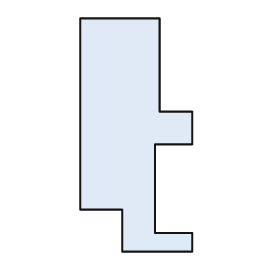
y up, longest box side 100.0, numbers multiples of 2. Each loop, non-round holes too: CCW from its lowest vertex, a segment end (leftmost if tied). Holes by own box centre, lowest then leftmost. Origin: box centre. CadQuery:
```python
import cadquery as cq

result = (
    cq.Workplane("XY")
    .moveTo(-6.0, -50.0)
    .lineTo(24.0, -50.0)
    .lineTo(24.0, -42.0)
    .lineTo(8.0, -42.0)
    .lineTo(8.0, -4.0)
    .lineTo(24.0, -4.0)
    .lineTo(24.0, 10.0)
    .lineTo(10.0, 10.0)
    .lineTo(10.0, 50.0)
    .lineTo(-24.0, 50.0)
    .lineTo(-24.0, -32.0)
    .lineTo(-6.0, -32.0)
    .close()
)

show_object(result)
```